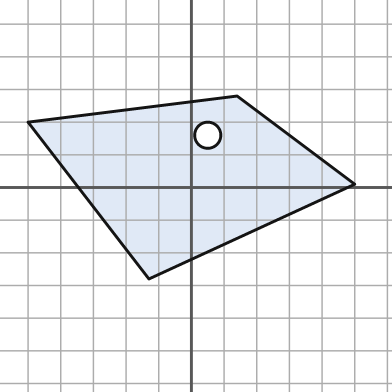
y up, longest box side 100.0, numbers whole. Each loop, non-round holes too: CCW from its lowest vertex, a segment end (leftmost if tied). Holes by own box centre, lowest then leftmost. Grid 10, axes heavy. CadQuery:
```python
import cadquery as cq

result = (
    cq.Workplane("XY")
    .moveTo(-13.0, -28.0)
    .lineTo(50.0, 1.0)
    .lineTo(14.0, 28.0)
    .lineTo(-50.0, 20.0)
    .close()
    .moveTo(5.0, 16.0)
    .circle(4.0)
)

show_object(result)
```